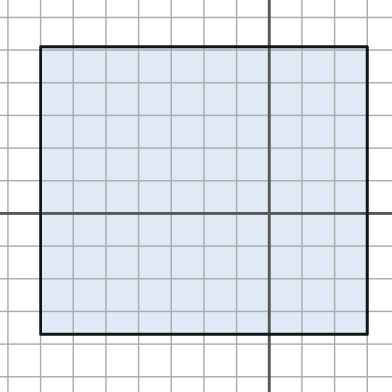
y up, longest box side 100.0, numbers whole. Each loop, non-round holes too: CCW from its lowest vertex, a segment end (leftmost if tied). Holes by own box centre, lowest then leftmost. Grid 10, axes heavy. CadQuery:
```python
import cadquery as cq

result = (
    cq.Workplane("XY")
    .moveTo(-70.0, -37.0)
    .lineTo(30.0, -37.0)
    .lineTo(30.0, 51.0)
    .lineTo(-70.0, 51.0)
    .close()
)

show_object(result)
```